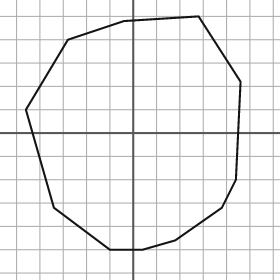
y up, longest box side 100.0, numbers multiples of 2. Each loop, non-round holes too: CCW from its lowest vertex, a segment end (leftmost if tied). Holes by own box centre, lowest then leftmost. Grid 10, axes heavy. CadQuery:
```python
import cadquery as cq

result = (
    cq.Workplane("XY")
    .moveTo(-10.0, -50.0)
    .lineTo(4.0, -50.0)
    .lineTo(18.0, -46.0)
    .lineTo(38.0, -32.0)
    .lineTo(44.0, -20.0)
    .lineTo(46.0, 22.0)
    .lineTo(28.0, 50.0)
    .lineTo(-4.0, 48.0)
    .lineTo(-28.0, 40.0)
    .lineTo(-46.0, 10.0)
    .lineTo(-34.0, -32.0)
    .close()
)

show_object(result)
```